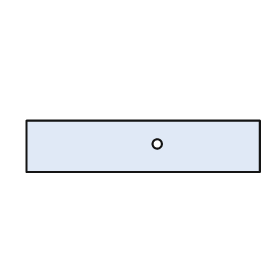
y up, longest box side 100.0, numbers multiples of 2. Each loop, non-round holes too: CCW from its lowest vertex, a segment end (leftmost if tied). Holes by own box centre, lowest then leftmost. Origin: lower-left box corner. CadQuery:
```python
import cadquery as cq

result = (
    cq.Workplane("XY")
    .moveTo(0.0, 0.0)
    .lineTo(100.0, 0.0)
    .lineTo(100.0, 22.0)
    .lineTo(0.0, 22.0)
    .close()
    .moveTo(56.0, 12.0)
    .circle(2.0)
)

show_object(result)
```